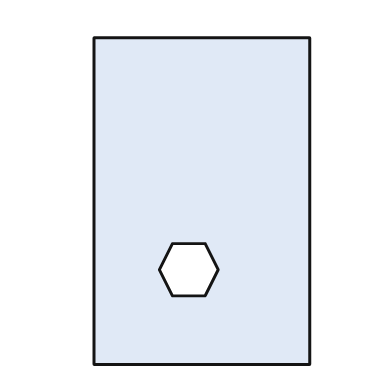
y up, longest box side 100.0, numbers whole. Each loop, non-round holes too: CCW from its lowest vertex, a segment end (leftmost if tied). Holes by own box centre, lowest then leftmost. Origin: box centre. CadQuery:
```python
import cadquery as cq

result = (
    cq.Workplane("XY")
    .moveTo(-33.0, -50.0)
    .lineTo(33.0, -50.0)
    .lineTo(33.0, 50.0)
    .lineTo(-33.0, 50.0)
    .close()
    .moveTo(-9.0, -29.0)
    .lineTo(1.0, -29.0)
    .lineTo(5.0, -21.0)
    .lineTo(1.0, -13.0)
    .lineTo(-9.0, -13.0)
    .lineTo(-13.0, -21.0)
    .close()
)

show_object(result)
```